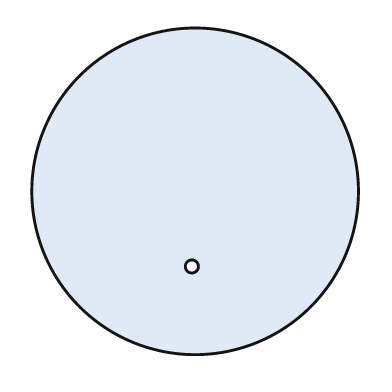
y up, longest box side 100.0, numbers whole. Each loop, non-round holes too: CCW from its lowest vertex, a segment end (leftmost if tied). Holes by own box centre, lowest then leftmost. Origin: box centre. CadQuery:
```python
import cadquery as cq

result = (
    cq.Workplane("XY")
    .moveTo(0.0, 0.0)
    .circle(50.0)
    .moveTo(-1.0, -23.0)
    .circle(2.0)
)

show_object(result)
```